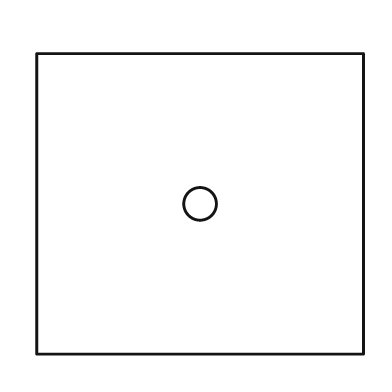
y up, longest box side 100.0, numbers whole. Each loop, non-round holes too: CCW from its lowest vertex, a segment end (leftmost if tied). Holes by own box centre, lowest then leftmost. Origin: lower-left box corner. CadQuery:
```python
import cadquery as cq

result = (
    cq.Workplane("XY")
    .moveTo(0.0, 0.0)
    .lineTo(100.0, 0.0)
    .lineTo(100.0, 92.0)
    .lineTo(0.0, 92.0)
    .close()
    .moveTo(50.0, 46.0)
    .circle(5.0)
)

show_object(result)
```